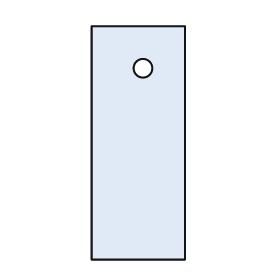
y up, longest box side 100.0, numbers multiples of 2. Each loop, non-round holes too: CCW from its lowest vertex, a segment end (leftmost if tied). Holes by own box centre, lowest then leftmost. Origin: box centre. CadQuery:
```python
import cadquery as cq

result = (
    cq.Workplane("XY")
    .moveTo(-20.0, -50.0)
    .lineTo(20.0, -50.0)
    .lineTo(20.0, 50.0)
    .lineTo(-20.0, 50.0)
    .close()
    .moveTo(2.0, 32.0)
    .circle(4.0)
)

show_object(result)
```